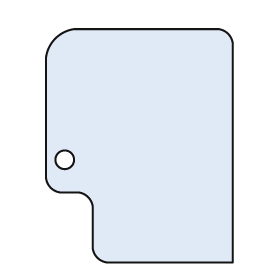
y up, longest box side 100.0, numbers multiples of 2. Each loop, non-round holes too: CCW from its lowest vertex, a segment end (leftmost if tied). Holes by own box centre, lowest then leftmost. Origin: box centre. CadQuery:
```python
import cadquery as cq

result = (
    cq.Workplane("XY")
    .moveTo(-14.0, -50.0)
    .lineTo(40.0, -50.0)
    .lineTo(40.0, 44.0)
    .threePointArc((38.0, 48.0), (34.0, 50.0))
    .lineTo(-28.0, 50.0)
    .threePointArc((-36.0, 46.0), (-40.0, 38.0))
    .lineTo(-40.0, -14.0)
    .threePointArc((-38.0, -18.0), (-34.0, -20.0))
    .lineTo(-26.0, -20.0)
    .threePointArc((-22.0, -22.0), (-20.0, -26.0))
    .lineTo(-20.0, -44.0)
    .threePointArc((-18.0, -48.0), (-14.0, -50.0))
    .close()
    .moveTo(-32.0, -6.0)
    .circle(4.0)
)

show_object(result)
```